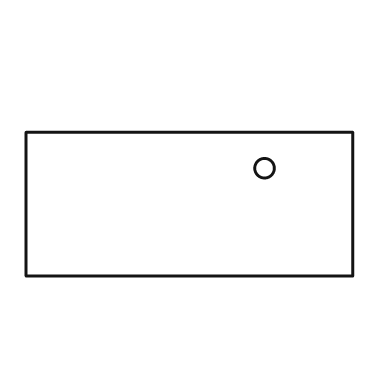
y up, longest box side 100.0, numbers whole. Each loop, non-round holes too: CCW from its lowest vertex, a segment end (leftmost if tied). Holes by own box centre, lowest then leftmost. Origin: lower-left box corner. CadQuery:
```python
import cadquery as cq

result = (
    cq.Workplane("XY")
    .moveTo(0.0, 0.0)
    .lineTo(100.0, 0.0)
    .lineTo(100.0, 44.0)
    .lineTo(0.0, 44.0)
    .close()
    .moveTo(73.0, 33.0)
    .circle(3.0)
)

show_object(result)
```